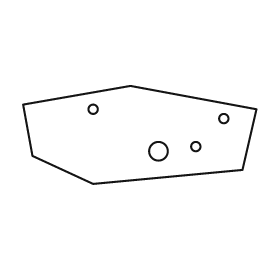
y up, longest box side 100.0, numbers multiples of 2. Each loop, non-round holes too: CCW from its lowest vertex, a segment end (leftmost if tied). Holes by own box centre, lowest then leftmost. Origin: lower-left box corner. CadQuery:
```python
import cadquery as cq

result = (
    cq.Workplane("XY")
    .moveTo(30.0, 0.0)
    .lineTo(94.0, 6.0)
    .lineTo(100.0, 32.0)
    .lineTo(46.0, 42.0)
    .lineTo(0.0, 34.0)
    .lineTo(4.0, 12.0)
    .close()
    .moveTo(58.0, 14.0)
    .circle(4.0)
    .moveTo(74.0, 16.0)
    .circle(2.0)
    .moveTo(86.0, 28.0)
    .circle(2.0)
    .moveTo(30.0, 32.0)
    .circle(2.0)
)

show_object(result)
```